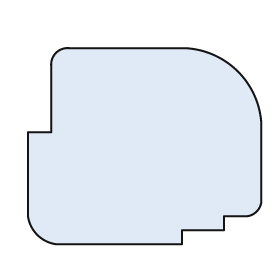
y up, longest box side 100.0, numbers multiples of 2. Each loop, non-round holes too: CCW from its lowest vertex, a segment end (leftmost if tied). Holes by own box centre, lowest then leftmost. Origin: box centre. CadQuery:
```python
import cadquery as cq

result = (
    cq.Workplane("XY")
    .moveTo(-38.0, -42.0)
    .lineTo(16.0, -42.0)
    .lineTo(16.0, -36.0)
    .lineTo(34.0, -36.0)
    .lineTo(34.0, -30.0)
    .lineTo(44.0, -30.0)
    .threePointArc((48.0, -28.0), (50.0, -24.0))
    .lineTo(50.0, 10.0)
    .threePointArc((40.0, 32.0), (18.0, 42.0))
    .lineTo(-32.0, 42.0)
    .threePointArc((-38.0, 40.0), (-40.0, 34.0))
    .lineTo(-40.0, 6.0)
    .lineTo(-50.0, 6.0)
    .lineTo(-50.0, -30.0)
    .threePointArc((-46.0, -38.0), (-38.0, -42.0))
    .close()
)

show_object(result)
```